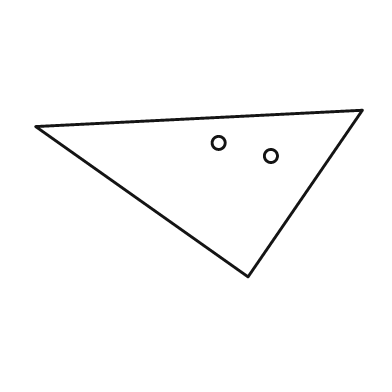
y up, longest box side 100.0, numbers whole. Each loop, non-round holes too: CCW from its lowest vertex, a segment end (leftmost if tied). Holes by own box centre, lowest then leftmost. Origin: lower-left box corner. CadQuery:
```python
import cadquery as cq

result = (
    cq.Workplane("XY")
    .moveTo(65.0, 0.0)
    .lineTo(100.0, 51.0)
    .lineTo(0.0, 46.0)
    .close()
    .moveTo(72.0, 37.0)
    .circle(2.0)
    .moveTo(56.0, 41.0)
    .circle(2.0)
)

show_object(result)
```